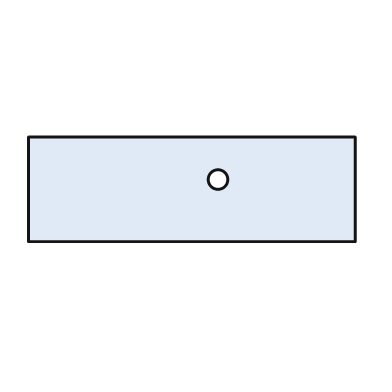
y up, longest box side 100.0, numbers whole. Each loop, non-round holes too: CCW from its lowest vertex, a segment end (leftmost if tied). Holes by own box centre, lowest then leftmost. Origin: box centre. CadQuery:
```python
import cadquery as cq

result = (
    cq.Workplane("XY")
    .moveTo(-50.0, -16.0)
    .lineTo(50.0, -16.0)
    .lineTo(50.0, 16.0)
    .lineTo(-50.0, 16.0)
    .close()
    .moveTo(8.0, 3.0)
    .circle(3.0)
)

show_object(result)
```